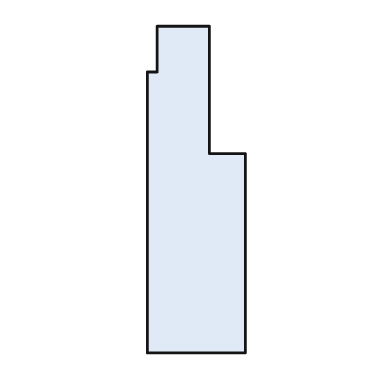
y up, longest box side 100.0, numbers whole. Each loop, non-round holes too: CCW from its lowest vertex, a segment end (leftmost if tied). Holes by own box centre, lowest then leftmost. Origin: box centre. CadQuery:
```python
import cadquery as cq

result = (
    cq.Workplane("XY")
    .moveTo(-15.0, -50.0)
    .lineTo(15.0, -50.0)
    .lineTo(15.0, 11.0)
    .lineTo(4.0, 11.0)
    .lineTo(4.0, 50.0)
    .lineTo(-12.0, 50.0)
    .lineTo(-12.0, 36.0)
    .lineTo(-15.0, 36.0)
    .close()
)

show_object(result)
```